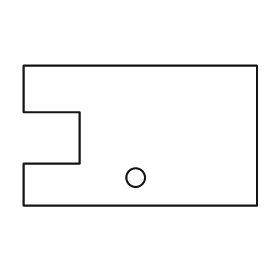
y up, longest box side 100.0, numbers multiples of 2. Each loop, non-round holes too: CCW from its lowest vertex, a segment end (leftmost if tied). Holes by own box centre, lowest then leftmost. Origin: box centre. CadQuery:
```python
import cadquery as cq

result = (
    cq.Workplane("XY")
    .moveTo(-50.0, -30.0)
    .lineTo(50.0, -30.0)
    .lineTo(50.0, 30.0)
    .lineTo(-50.0, 30.0)
    .lineTo(-50.0, 10.0)
    .lineTo(-26.0, 10.0)
    .lineTo(-26.0, -12.0)
    .lineTo(-50.0, -12.0)
    .close()
    .moveTo(-2.0, -18.0)
    .circle(4.0)
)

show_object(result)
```